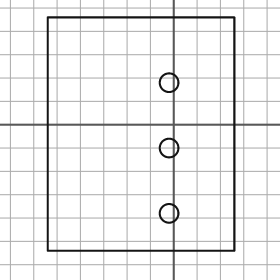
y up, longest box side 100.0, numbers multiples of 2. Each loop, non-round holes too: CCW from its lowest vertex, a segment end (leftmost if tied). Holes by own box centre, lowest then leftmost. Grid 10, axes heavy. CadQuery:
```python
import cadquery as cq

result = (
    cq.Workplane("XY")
    .moveTo(-54.0, -54.0)
    .lineTo(26.0, -54.0)
    .lineTo(26.0, 46.0)
    .lineTo(-54.0, 46.0)
    .close()
    .moveTo(-2.0, -38.0)
    .circle(4.0)
    .moveTo(-2.0, -10.0)
    .circle(4.0)
    .moveTo(-2.0, 18.0)
    .circle(4.0)
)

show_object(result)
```